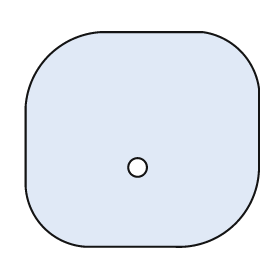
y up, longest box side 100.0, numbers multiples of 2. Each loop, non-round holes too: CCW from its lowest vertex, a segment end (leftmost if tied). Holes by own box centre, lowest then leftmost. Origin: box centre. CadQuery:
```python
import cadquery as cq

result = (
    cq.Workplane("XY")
    .moveTo(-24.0, -46.0)
    .lineTo(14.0, -46.0)
    .threePointArc((40.0, -36.0), (50.0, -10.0))
    .lineTo(50.0, 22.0)
    .threePointArc((42.0, 38.0), (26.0, 46.0))
    .lineTo(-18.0, 46.0)
    .threePointArc((-40.0, 36.0), (-50.0, 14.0))
    .lineTo(-50.0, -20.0)
    .threePointArc((-42.0, -38.0), (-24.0, -46.0))
    .close()
    .moveTo(-2.0, -12.0)
    .circle(4.0)
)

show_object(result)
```